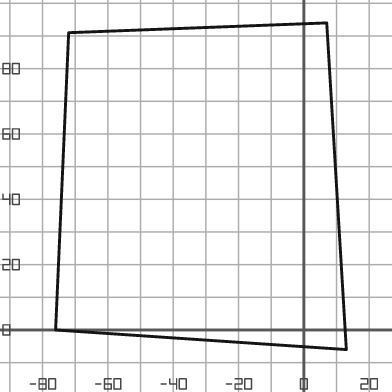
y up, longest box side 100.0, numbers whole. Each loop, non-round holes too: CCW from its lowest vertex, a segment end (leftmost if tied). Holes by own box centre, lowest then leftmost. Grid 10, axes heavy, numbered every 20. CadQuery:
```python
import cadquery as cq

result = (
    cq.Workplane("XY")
    .moveTo(13.0, -6.0)
    .lineTo(7.0, 94.0)
    .lineTo(-72.0, 91.0)
    .lineTo(-76.0, 0.0)
    .close()
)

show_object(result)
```